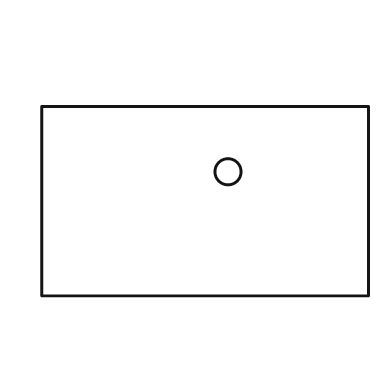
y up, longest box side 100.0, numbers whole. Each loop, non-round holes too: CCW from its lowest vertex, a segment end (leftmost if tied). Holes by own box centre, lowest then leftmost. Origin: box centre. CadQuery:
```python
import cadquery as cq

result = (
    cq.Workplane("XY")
    .moveTo(-50.0, -29.0)
    .lineTo(50.0, -29.0)
    .lineTo(50.0, 29.0)
    .lineTo(-50.0, 29.0)
    .close()
    .moveTo(7.0, 9.0)
    .circle(4.0)
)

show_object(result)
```